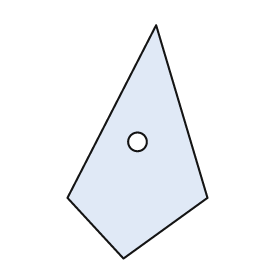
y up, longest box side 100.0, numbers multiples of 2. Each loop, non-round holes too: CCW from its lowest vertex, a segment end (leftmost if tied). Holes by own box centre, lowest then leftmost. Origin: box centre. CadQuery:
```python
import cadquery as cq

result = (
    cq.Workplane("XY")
    .moveTo(-6.0, -50.0)
    .lineTo(30.0, -24.0)
    .lineTo(8.0, 50.0)
    .lineTo(-30.0, -24.0)
    .close()
    .moveTo(0.0, 0.0)
    .circle(4.0)
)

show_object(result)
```